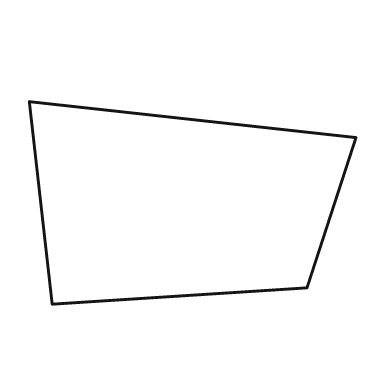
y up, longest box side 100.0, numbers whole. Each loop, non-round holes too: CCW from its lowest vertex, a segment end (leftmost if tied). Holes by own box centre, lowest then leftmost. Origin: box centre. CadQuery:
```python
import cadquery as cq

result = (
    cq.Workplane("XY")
    .moveTo(-43.0, -31.0)
    .lineTo(35.0, -26.0)
    .lineTo(50.0, 20.0)
    .lineTo(-50.0, 31.0)
    .close()
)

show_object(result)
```